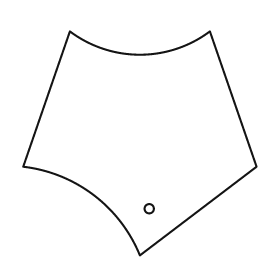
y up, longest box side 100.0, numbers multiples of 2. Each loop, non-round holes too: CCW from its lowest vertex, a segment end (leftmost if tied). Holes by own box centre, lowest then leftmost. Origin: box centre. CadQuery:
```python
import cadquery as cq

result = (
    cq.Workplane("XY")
    .moveTo(0.0, -48.0)
    .lineTo(50.0, -10.0)
    .lineTo(30.0, 48.0)
    .threePointArc((0.0, 38.0), (-30.0, 48.0))
    .lineTo(-50.0, -10.0)
    .threePointArc((-20.0, -22.0), (0.0, -48.0))
    .close()
    .moveTo(4.0, -28.0)
    .circle(2.0)
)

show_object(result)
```